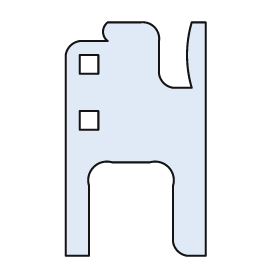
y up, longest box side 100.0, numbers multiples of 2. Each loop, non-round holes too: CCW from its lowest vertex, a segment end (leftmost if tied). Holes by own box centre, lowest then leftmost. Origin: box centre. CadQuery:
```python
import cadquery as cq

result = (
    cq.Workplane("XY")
    .moveTo(-30.0, -50.0)
    .lineTo(-20.0, -50.0)
    .lineTo(-20.0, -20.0)
    .threePointArc((-18.0, -12.0), (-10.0, -10.0))
    .lineTo(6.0, -10.0)
    .threePointArc((14.0, -12.0), (16.0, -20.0))
    .lineTo(16.0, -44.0)
    .threePointArc((18.0, -48.0), (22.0, -50.0))
    .lineTo(30.0, -50.0)
    .lineTo(30.0, 50.0)
    .lineTo(24.0, 50.0)
    .threePointArc((22.0, 36.0), (24.0, 22.0))
    .lineTo(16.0, 22.0)
    .threePointArc((12.0, 24.0), (10.0, 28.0))
    .lineTo(10.0, 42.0)
    .threePointArc((8.0, 48.0), (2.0, 50.0))
    .lineTo(-12.0, 50.0)
    .threePointArc((-14.0, 46.0), (-12.0, 42.0))
    .lineTo(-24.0, 42.0)
    .threePointArc((-28.0, 40.0), (-30.0, 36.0))
    .close()
    .moveTo(-24.0, 4.0)
    .lineTo(-16.0, 4.0)
    .lineTo(-16.0, 12.0)
    .lineTo(-24.0, 12.0)
    .close()
    .moveTo(-24.0, 28.0)
    .lineTo(-16.0, 28.0)
    .lineTo(-16.0, 36.0)
    .lineTo(-24.0, 36.0)
    .close()
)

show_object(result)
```